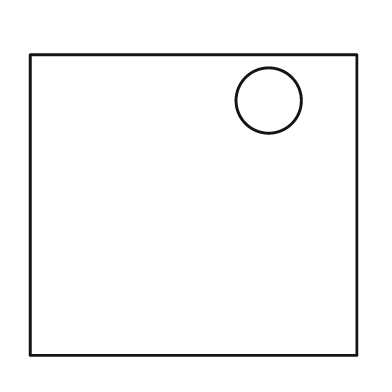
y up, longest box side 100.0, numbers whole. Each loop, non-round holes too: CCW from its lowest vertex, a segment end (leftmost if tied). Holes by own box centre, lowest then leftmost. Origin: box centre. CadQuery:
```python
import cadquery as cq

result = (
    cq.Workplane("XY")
    .moveTo(-50.0, -46.0)
    .lineTo(50.0, -46.0)
    .lineTo(50.0, 46.0)
    .lineTo(-50.0, 46.0)
    .close()
    .moveTo(23.0, 32.0)
    .circle(10.0)
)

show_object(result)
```